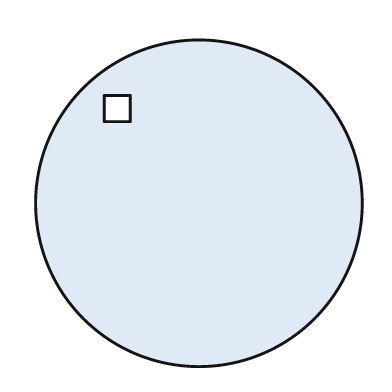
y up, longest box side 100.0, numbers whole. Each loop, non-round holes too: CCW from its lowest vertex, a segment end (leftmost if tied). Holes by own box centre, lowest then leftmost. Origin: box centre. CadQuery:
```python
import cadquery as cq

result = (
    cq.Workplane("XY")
    .moveTo(0.0, 0.0)
    .circle(50.0)
    .moveTo(-29.0, 25.0)
    .lineTo(-21.0, 25.0)
    .lineTo(-21.0, 33.0)
    .lineTo(-29.0, 33.0)
    .close()
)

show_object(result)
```